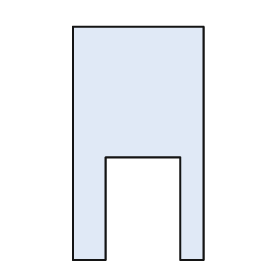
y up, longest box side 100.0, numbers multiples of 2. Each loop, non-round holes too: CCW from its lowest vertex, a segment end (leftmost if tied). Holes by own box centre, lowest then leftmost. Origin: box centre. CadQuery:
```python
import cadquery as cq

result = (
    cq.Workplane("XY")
    .moveTo(-28.0, -50.0)
    .lineTo(-14.0, -50.0)
    .lineTo(-14.0, -6.0)
    .lineTo(18.0, -6.0)
    .lineTo(18.0, -50.0)
    .lineTo(28.0, -50.0)
    .lineTo(28.0, 50.0)
    .lineTo(-28.0, 50.0)
    .close()
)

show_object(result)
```